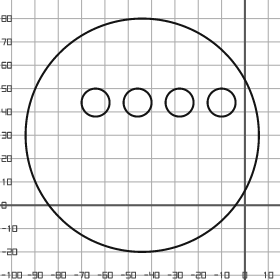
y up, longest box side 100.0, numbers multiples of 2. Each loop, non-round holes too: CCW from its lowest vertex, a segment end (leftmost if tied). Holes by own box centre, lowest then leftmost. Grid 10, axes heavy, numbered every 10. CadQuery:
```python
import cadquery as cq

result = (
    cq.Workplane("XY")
    .moveTo(-44.0, 30.0)
    .circle(50.0)
    .moveTo(-64.0, 44.0)
    .circle(6.0)
    .moveTo(-46.0, 44.0)
    .circle(6.0)
    .moveTo(-28.0, 44.0)
    .circle(6.0)
    .moveTo(-10.0, 44.0)
    .circle(6.0)
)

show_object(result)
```